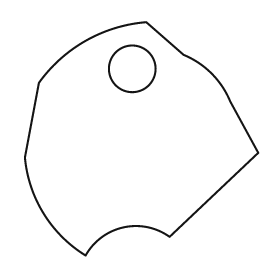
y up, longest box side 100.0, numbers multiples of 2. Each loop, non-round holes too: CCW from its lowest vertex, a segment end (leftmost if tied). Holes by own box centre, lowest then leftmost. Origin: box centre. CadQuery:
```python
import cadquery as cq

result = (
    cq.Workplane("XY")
    .moveTo(-24.0, -50.0)
    .threePointArc((-8.0, -38.0), (12.0, -42.0))
    .lineTo(50.0, -6.0)
    .lineTo(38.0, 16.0)
    .threePointArc((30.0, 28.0), (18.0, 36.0))
    .lineTo(2.0, 50.0)
    .threePointArc((-24.0, 42.0), (-44.0, 24.0))
    .lineTo(-50.0, -8.0)
    .threePointArc((-42.0, -32.0), (-24.0, -50.0))
    .close()
    .moveTo(-4.0, 30.0)
    .circle(10.0)
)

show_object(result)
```